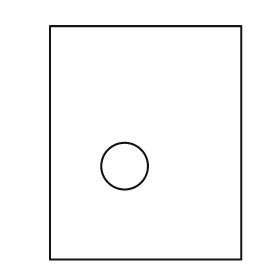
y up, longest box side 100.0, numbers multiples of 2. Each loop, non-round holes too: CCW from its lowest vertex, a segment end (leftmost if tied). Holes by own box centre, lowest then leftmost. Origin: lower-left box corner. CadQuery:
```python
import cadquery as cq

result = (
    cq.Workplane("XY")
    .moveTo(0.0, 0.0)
    .lineTo(82.0, 0.0)
    .lineTo(82.0, 100.0)
    .lineTo(0.0, 100.0)
    .close()
    .moveTo(32.0, 40.0)
    .circle(10.0)
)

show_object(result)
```